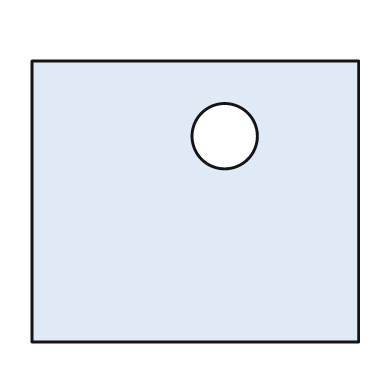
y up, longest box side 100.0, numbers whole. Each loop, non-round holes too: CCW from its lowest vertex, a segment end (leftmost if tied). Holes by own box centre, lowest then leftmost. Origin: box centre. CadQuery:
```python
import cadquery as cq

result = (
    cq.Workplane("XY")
    .moveTo(-50.0, -43.0)
    .lineTo(50.0, -43.0)
    .lineTo(50.0, 43.0)
    .lineTo(-50.0, 43.0)
    .close()
    .moveTo(9.0, 20.0)
    .circle(10.0)
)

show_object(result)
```